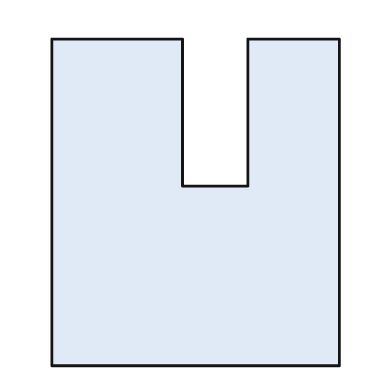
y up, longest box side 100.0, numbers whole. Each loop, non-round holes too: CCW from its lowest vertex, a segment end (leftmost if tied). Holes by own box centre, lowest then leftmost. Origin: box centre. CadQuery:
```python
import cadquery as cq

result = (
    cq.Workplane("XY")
    .moveTo(-44.0, -50.0)
    .lineTo(44.0, -50.0)
    .lineTo(44.0, 50.0)
    .lineTo(16.0, 50.0)
    .lineTo(16.0, 5.0)
    .lineTo(-4.0, 5.0)
    .lineTo(-4.0, 50.0)
    .lineTo(-44.0, 50.0)
    .close()
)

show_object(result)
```